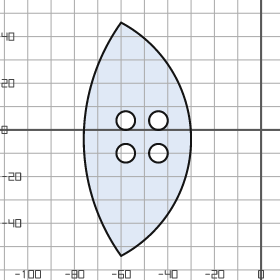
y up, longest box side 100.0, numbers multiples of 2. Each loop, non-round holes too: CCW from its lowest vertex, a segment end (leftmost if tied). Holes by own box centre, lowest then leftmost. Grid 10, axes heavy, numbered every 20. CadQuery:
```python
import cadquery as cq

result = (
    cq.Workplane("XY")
    .moveTo(-60.0, -54.0)
    .threePointArc((-30.0, -4.0), (-60.0, 46.0))
    .threePointArc((-76.0, -4.0), (-60.0, -54.0))
    .close()
    .moveTo(-58.0, -10.0)
    .circle(4.0)
    .moveTo(-44.0, -10.0)
    .circle(4.0)
    .moveTo(-58.0, 4.0)
    .circle(4.0)
    .moveTo(-44.0, 4.0)
    .circle(4.0)
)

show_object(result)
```